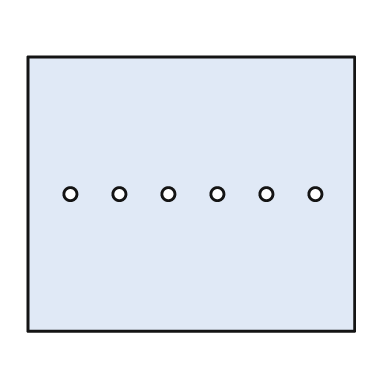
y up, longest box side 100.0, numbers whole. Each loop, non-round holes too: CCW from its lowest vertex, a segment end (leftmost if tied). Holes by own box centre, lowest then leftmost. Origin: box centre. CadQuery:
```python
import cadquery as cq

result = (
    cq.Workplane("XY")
    .moveTo(-50.0, -42.0)
    .lineTo(50.0, -42.0)
    .lineTo(50.0, 42.0)
    .lineTo(-50.0, 42.0)
    .close()
    .moveTo(-37.0, 0.0)
    .circle(2.0)
    .moveTo(-22.0, 0.0)
    .circle(2.0)
    .moveTo(-7.0, 0.0)
    .circle(2.0)
    .moveTo(8.0, 0.0)
    .circle(2.0)
    .moveTo(23.0, 0.0)
    .circle(2.0)
    .moveTo(38.0, 0.0)
    .circle(2.0)
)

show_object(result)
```